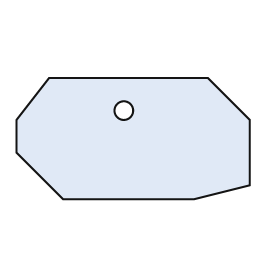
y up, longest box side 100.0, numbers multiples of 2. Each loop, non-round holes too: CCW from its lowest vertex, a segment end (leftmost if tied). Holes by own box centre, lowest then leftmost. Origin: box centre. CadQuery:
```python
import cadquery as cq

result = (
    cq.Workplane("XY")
    .moveTo(-30.0, -26.0)
    .lineTo(26.0, -26.0)
    .lineTo(50.0, -20.0)
    .lineTo(50.0, 8.0)
    .lineTo(32.0, 26.0)
    .lineTo(-36.0, 26.0)
    .lineTo(-50.0, 8.0)
    .lineTo(-50.0, -6.0)
    .close()
    .moveTo(-4.0, 12.0)
    .circle(4.0)
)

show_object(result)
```